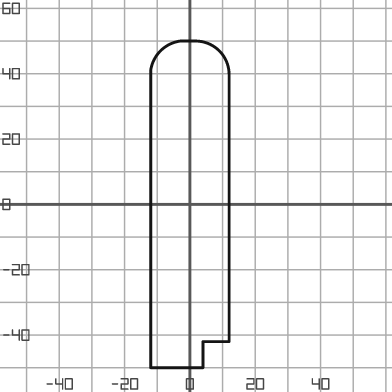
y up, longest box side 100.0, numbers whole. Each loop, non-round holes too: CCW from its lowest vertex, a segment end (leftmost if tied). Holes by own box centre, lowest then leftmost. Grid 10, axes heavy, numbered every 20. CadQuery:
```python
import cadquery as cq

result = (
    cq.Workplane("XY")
    .moveTo(-12.0, -50.0)
    .lineTo(4.0, -50.0)
    .lineTo(4.0, -42.0)
    .lineTo(12.0, -42.0)
    .lineTo(12.0, 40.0)
    .threePointArc((9.0, 47.0), (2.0, 50.0))
    .lineTo(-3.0, 50.0)
    .threePointArc((-9.0, 47.0), (-12.0, 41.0))
    .close()
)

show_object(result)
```